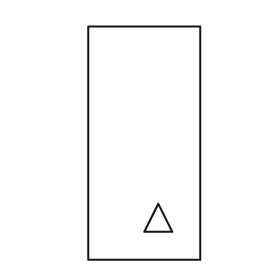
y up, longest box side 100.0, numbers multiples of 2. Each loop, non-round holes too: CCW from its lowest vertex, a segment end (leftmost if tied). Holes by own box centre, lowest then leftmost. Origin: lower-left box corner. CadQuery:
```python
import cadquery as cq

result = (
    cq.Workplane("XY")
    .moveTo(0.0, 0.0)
    .lineTo(48.0, 0.0)
    .lineTo(48.0, 100.0)
    .lineTo(0.0, 100.0)
    .close()
    .moveTo(24.0, 12.0)
    .lineTo(36.0, 12.0)
    .lineTo(30.0, 24.0)
    .close()
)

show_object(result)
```